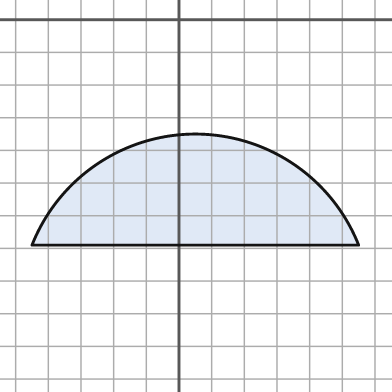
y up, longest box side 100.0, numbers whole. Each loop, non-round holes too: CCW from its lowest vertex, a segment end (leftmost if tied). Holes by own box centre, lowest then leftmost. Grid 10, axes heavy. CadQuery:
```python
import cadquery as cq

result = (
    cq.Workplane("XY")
    .moveTo(-45.0, -69.0)
    .lineTo(55.0, -69.0)
    .threePointArc((5.0, -35.0), (-45.0, -69.0))
    .close()
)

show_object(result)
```